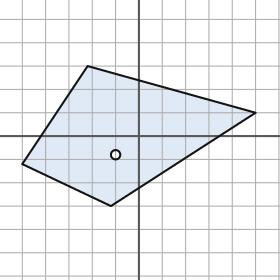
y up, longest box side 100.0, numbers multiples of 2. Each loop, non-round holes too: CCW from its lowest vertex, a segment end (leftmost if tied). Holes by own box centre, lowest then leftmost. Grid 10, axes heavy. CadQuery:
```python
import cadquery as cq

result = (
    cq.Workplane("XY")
    .moveTo(-12.0, -30.0)
    .lineTo(50.0, 10.0)
    .lineTo(-22.0, 30.0)
    .lineTo(-50.0, -12.0)
    .close()
    .moveTo(-10.0, -8.0)
    .circle(2.0)
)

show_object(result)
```